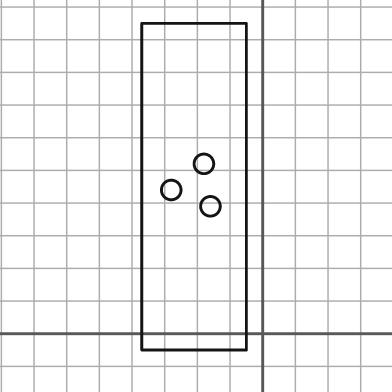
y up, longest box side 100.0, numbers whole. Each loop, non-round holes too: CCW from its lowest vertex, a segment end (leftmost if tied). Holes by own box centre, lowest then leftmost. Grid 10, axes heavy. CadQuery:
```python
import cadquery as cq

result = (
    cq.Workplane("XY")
    .moveTo(-37.0, -5.0)
    .lineTo(-5.0, -5.0)
    .lineTo(-5.0, 95.0)
    .lineTo(-37.0, 95.0)
    .close()
    .moveTo(-16.0, 39.0)
    .circle(3.0)
    .moveTo(-28.0, 44.0)
    .circle(3.0)
    .moveTo(-18.0, 52.0)
    .circle(3.0)
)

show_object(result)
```